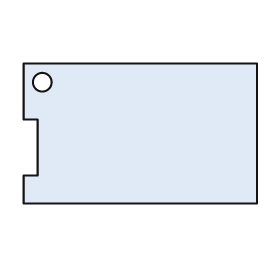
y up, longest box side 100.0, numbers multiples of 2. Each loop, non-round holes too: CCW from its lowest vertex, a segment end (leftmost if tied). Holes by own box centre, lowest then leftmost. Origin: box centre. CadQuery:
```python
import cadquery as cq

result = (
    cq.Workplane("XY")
    .moveTo(-50.0, -30.0)
    .lineTo(50.0, -30.0)
    .lineTo(50.0, 30.0)
    .lineTo(-50.0, 30.0)
    .lineTo(-50.0, 6.0)
    .lineTo(-44.0, 6.0)
    .lineTo(-44.0, -18.0)
    .lineTo(-50.0, -18.0)
    .close()
    .moveTo(-42.0, 22.0)
    .circle(4.0)
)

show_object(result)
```